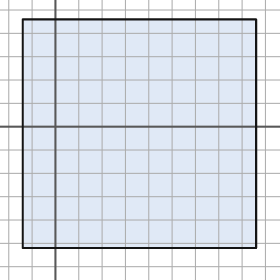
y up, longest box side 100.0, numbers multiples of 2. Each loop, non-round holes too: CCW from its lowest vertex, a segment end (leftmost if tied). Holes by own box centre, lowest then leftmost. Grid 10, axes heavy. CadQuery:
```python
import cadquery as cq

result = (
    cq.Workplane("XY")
    .moveTo(-14.0, -52.0)
    .lineTo(86.0, -52.0)
    .lineTo(86.0, 46.0)
    .lineTo(-14.0, 46.0)
    .close()
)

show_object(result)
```